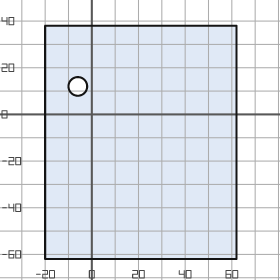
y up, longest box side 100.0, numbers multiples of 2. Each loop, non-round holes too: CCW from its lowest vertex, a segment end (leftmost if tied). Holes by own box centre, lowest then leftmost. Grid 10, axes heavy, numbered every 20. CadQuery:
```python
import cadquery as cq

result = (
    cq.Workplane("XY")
    .moveTo(-20.0, -62.0)
    .lineTo(62.0, -62.0)
    .lineTo(62.0, 38.0)
    .lineTo(-20.0, 38.0)
    .close()
    .moveTo(-6.0, 12.0)
    .circle(4.0)
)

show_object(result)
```